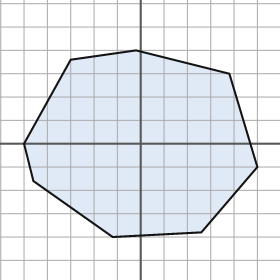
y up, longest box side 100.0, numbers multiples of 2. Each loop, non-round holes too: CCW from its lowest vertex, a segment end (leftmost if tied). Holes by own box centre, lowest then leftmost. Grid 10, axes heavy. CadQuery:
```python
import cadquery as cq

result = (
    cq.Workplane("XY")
    .moveTo(-12.0, -40.0)
    .lineTo(26.0, -38.0)
    .lineTo(50.0, -10.0)
    .lineTo(38.0, 30.0)
    .lineTo(-2.0, 40.0)
    .lineTo(-30.0, 36.0)
    .lineTo(-50.0, 0.0)
    .lineTo(-46.0, -16.0)
    .close()
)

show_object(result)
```